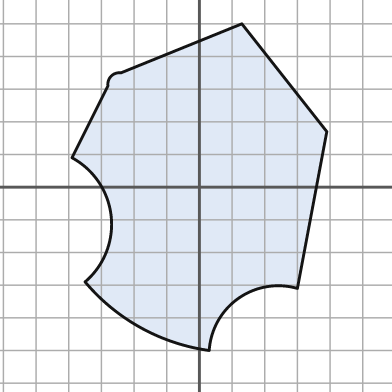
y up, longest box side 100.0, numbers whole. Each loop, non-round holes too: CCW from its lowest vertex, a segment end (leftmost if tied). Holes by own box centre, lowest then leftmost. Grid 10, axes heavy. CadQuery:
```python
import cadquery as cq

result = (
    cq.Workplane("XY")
    .moveTo(3.0, -50.0)
    .threePointArc((12.0, -34.0), (30.0, -31.0))
    .lineTo(39.0, 17.0)
    .lineTo(13.0, 50.0)
    .lineTo(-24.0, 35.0)
    .threePointArc((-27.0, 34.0), (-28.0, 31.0))
    .lineTo(-39.0, 9.0)
    .threePointArc((-27.0, -9.0), (-35.0, -29.0))
    .threePointArc((-18.0, -43.0), (3.0, -50.0))
    .close()
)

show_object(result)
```